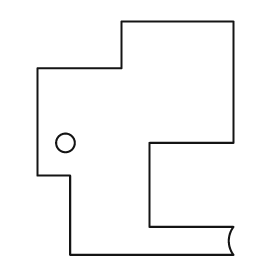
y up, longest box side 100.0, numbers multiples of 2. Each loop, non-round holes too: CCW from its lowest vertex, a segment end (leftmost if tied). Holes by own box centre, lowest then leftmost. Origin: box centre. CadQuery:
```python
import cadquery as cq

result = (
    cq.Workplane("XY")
    .moveTo(-28.0, -50.0)
    .lineTo(42.0, -50.0)
    .threePointArc((40.0, -44.0), (42.0, -38.0))
    .lineTo(6.0, -38.0)
    .lineTo(6.0, -2.0)
    .lineTo(42.0, -2.0)
    .lineTo(42.0, 50.0)
    .lineTo(-6.0, 50.0)
    .lineTo(-6.0, 30.0)
    .lineTo(-42.0, 30.0)
    .lineTo(-42.0, -16.0)
    .lineTo(-28.0, -16.0)
    .close()
    .moveTo(-30.0, -2.0)
    .circle(4.0)
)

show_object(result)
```